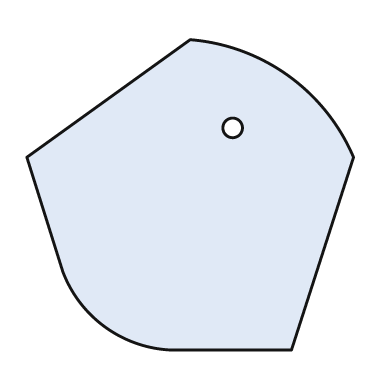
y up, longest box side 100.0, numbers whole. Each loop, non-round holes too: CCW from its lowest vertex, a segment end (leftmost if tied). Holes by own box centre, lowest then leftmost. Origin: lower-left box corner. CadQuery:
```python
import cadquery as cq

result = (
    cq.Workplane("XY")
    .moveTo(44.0, 0.0)
    .lineTo(81.0, 0.0)
    .lineTo(100.0, 59.0)
    .threePointArc((80.0, 84.0), (50.0, 95.0))
    .lineTo(0.0, 59.0)
    .lineTo(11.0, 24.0)
    .threePointArc((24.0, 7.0), (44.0, 0.0))
    .close()
    .moveTo(63.0, 68.0)
    .circle(3.0)
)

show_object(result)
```